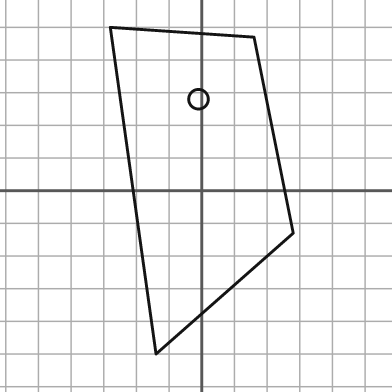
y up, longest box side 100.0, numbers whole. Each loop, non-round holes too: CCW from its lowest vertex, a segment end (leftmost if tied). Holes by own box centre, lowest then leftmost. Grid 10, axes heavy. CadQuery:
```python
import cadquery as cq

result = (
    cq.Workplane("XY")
    .moveTo(-14.0, -50.0)
    .lineTo(28.0, -13.0)
    .lineTo(16.0, 47.0)
    .lineTo(-28.0, 50.0)
    .close()
    .moveTo(-1.0, 28.0)
    .circle(3.0)
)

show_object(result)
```